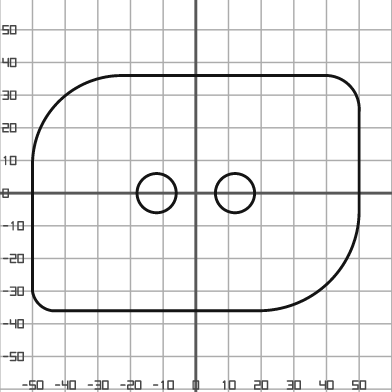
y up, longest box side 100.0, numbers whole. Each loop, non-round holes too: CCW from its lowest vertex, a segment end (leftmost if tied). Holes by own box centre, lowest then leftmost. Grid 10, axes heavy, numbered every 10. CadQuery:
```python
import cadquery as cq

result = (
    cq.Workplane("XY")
    .moveTo(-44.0, -36.0)
    .lineTo(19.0, -36.0)
    .threePointArc((41.0, -27.0), (50.0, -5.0))
    .lineTo(50.0, 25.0)
    .threePointArc((47.0, 33.0), (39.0, 36.0))
    .lineTo(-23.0, 36.0)
    .threePointArc((-42.0, 28.0), (-50.0, 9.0))
    .lineTo(-50.0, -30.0)
    .threePointArc((-48.0, -34.0), (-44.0, -36.0))
    .close()
    .moveTo(-12.0, 0.0)
    .circle(6.0)
    .moveTo(12.0, 0.0)
    .circle(6.0)
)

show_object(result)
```